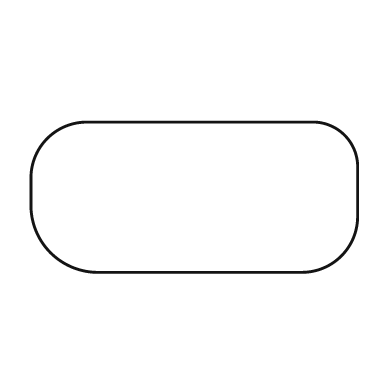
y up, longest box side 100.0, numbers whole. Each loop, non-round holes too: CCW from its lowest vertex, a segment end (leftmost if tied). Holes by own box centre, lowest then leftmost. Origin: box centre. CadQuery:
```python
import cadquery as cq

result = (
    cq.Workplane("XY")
    .moveTo(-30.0, -23.0)
    .lineTo(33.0, -23.0)
    .threePointArc((45.0, -18.0), (50.0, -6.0))
    .lineTo(50.0, 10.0)
    .threePointArc((46.0, 19.0), (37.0, 23.0))
    .lineTo(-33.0, 23.0)
    .threePointArc((-45.0, 18.0), (-50.0, 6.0))
    .lineTo(-50.0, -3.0)
    .threePointArc((-44.0, -17.0), (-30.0, -23.0))
    .close()
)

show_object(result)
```